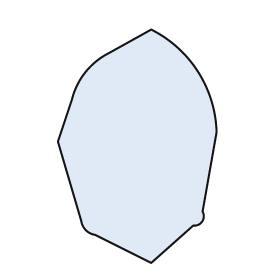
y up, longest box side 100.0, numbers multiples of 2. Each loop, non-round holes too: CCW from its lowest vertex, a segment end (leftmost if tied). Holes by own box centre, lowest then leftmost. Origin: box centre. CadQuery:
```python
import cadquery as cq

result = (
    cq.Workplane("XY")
    .moveTo(6.0, -50.0)
    .lineTo(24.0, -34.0)
    .threePointArc((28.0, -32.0), (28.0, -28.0))
    .lineTo(34.0, 6.0)
    .threePointArc((26.0, 32.0), (6.0, 50.0))
    .lineTo(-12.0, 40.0)
    .threePointArc((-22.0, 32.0), (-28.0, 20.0))
    .lineTo(-34.0, 2.0)
    .lineTo(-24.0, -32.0)
    .threePointArc((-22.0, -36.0), (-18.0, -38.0))
    .close()
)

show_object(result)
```